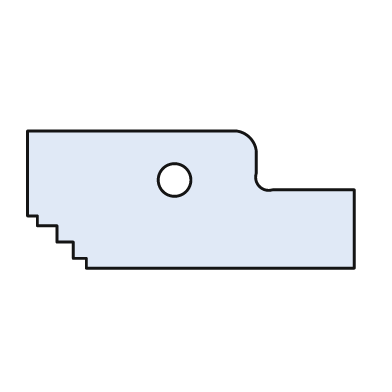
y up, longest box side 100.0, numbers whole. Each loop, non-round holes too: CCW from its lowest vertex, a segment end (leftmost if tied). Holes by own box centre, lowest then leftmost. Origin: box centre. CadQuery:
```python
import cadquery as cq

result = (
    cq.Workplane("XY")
    .moveTo(-32.0, -21.0)
    .lineTo(50.0, -21.0)
    .lineTo(50.0, 3.0)
    .lineTo(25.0, 3.0)
    .threePointArc((21.0, 4.0), (20.0, 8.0))
    .lineTo(20.0, 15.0)
    .threePointArc((18.0, 19.0), (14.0, 21.0))
    .lineTo(-50.0, 21.0)
    .lineTo(-50.0, -5.0)
    .lineTo(-47.0, -5.0)
    .lineTo(-47.0, -8.0)
    .lineTo(-41.0, -8.0)
    .lineTo(-41.0, -13.0)
    .lineTo(-36.0, -13.0)
    .lineTo(-36.0, -18.0)
    .lineTo(-32.0, -18.0)
    .close()
    .moveTo(-5.0, 6.0)
    .circle(5.0)
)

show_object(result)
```